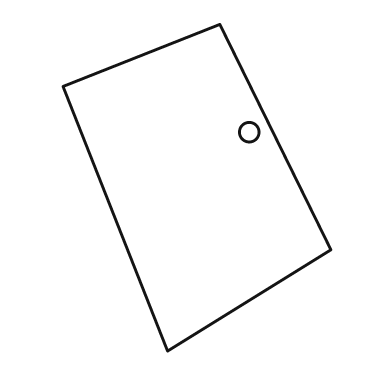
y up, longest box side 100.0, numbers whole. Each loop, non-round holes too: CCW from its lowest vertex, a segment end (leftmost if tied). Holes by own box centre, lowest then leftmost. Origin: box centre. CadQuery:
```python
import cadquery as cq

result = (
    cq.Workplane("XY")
    .moveTo(-9.0, -50.0)
    .lineTo(41.0, -19.0)
    .lineTo(7.0, 50.0)
    .lineTo(-41.0, 31.0)
    .close()
    .moveTo(16.0, 17.0)
    .circle(3.0)
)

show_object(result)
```